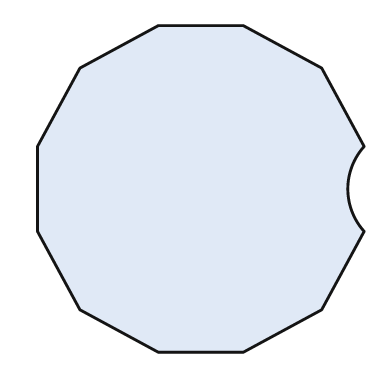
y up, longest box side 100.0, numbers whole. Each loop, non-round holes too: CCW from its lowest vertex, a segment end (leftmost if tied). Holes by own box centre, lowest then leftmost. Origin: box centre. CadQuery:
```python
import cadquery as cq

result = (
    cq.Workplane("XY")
    .moveTo(-13.0, -50.0)
    .lineTo(13.0, -50.0)
    .lineTo(37.0, -37.0)
    .lineTo(50.0, -13.0)
    .threePointArc((45.0, 0.0), (50.0, 13.0))
    .lineTo(37.0, 37.0)
    .lineTo(13.0, 50.0)
    .lineTo(-13.0, 50.0)
    .lineTo(-37.0, 37.0)
    .lineTo(-50.0, 13.0)
    .lineTo(-50.0, -13.0)
    .lineTo(-37.0, -37.0)
    .close()
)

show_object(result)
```